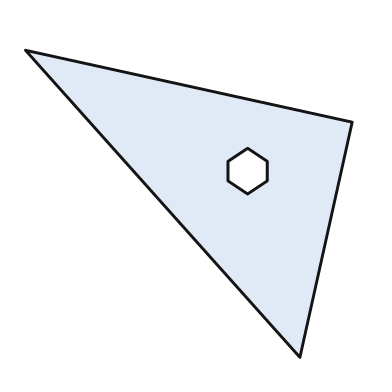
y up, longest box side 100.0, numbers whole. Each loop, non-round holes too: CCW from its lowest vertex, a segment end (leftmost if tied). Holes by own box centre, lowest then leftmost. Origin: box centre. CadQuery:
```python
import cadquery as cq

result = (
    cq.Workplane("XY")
    .moveTo(34.0, -47.0)
    .lineTo(50.0, 25.0)
    .lineTo(-50.0, 47.0)
    .close()
    .moveTo(18.0, 3.0)
    .lineTo(24.0, 7.0)
    .lineTo(24.0, 13.0)
    .lineTo(18.0, 17.0)
    .lineTo(12.0, 13.0)
    .lineTo(12.0, 7.0)
    .close()
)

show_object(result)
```